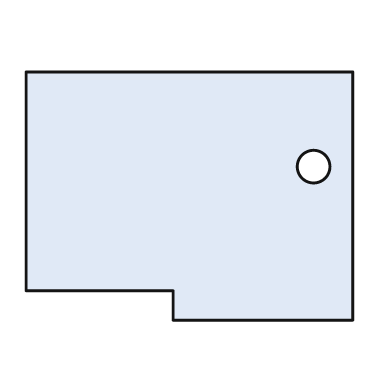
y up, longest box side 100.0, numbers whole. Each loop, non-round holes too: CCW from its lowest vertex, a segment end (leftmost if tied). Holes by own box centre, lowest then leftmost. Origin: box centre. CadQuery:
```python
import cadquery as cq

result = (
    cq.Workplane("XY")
    .moveTo(-5.0, -38.0)
    .lineTo(50.0, -38.0)
    .lineTo(50.0, 38.0)
    .lineTo(-50.0, 38.0)
    .lineTo(-50.0, -29.0)
    .lineTo(-5.0, -29.0)
    .close()
    .moveTo(38.0, 9.0)
    .circle(5.0)
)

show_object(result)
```